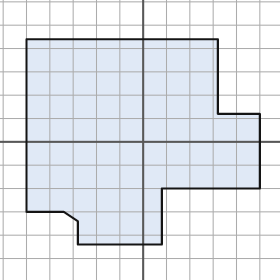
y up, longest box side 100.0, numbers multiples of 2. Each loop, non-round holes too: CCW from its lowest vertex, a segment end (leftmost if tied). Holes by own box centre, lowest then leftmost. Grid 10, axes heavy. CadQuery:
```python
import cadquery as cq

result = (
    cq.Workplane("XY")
    .moveTo(-28.0, -44.0)
    .lineTo(8.0, -44.0)
    .lineTo(8.0, -20.0)
    .lineTo(50.0, -20.0)
    .lineTo(50.0, 12.0)
    .lineTo(32.0, 12.0)
    .lineTo(32.0, 44.0)
    .lineTo(-50.0, 44.0)
    .lineTo(-50.0, -30.0)
    .lineTo(-34.0, -30.0)
    .lineTo(-28.0, -34.0)
    .close()
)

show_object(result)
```